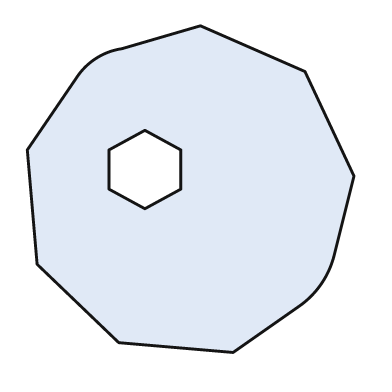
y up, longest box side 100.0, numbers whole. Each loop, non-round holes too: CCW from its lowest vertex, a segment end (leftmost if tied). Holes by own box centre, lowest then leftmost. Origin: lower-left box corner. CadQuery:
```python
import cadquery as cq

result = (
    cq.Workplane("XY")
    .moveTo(63.0, 0.0)
    .lineTo(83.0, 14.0)
    .threePointArc((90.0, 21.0), (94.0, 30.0))
    .lineTo(100.0, 54.0)
    .lineTo(85.0, 86.0)
    .lineTo(53.0, 100.0)
    .lineTo(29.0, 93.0)
    .threePointArc((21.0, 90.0), (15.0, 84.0))
    .lineTo(0.0, 62.0)
    .lineTo(3.0, 27.0)
    .lineTo(28.0, 3.0)
    .close()
    .moveTo(36.0, 44.0)
    .lineTo(47.0, 50.0)
    .lineTo(47.0, 62.0)
    .lineTo(36.0, 68.0)
    .lineTo(25.0, 62.0)
    .lineTo(25.0, 50.0)
    .close()
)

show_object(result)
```